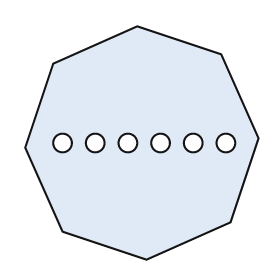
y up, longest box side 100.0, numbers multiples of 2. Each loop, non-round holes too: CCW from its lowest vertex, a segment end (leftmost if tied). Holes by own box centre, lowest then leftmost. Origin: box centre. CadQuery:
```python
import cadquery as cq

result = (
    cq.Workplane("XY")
    .moveTo(2.0, -50.0)
    .lineTo(38.0, -34.0)
    .lineTo(50.0, 2.0)
    .lineTo(34.0, 38.0)
    .lineTo(-2.0, 50.0)
    .lineTo(-38.0, 34.0)
    .lineTo(-50.0, -2.0)
    .lineTo(-34.0, -38.0)
    .close()
    .moveTo(-34.0, 0.0)
    .circle(4.0)
    .moveTo(-20.0, 0.0)
    .circle(4.0)
    .moveTo(-6.0, 0.0)
    .circle(4.0)
    .moveTo(8.0, 0.0)
    .circle(4.0)
    .moveTo(22.0, 0.0)
    .circle(4.0)
    .moveTo(36.0, 0.0)
    .circle(4.0)
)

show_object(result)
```